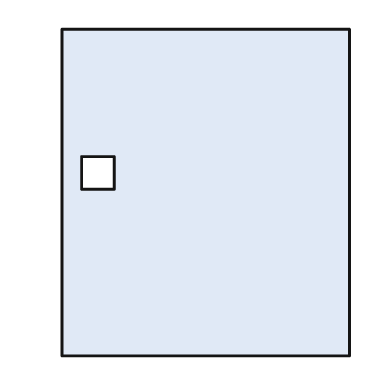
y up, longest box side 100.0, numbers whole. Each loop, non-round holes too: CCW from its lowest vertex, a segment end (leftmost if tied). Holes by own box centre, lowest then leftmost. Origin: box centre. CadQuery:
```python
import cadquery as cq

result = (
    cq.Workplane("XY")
    .moveTo(-44.0, -50.0)
    .lineTo(44.0, -50.0)
    .lineTo(44.0, 50.0)
    .lineTo(-44.0, 50.0)
    .close()
    .moveTo(-38.0, 1.0)
    .lineTo(-28.0, 1.0)
    .lineTo(-28.0, 11.0)
    .lineTo(-38.0, 11.0)
    .close()
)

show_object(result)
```